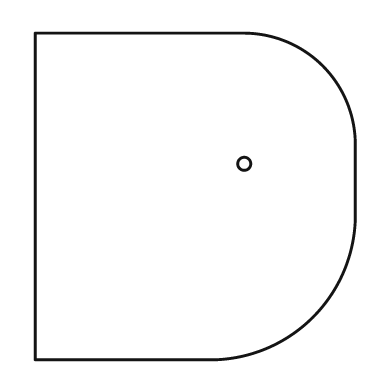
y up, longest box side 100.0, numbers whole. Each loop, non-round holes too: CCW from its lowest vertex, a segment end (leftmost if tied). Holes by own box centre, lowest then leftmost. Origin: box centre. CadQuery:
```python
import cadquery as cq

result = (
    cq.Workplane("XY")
    .moveTo(-49.0, -50.0)
    .lineTo(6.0, -50.0)
    .threePointArc((36.0, -37.0), (49.0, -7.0))
    .lineTo(49.0, 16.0)
    .threePointArc((39.0, 40.0), (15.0, 50.0))
    .lineTo(-49.0, 50.0)
    .close()
    .moveTo(15.0, 10.0)
    .circle(2.0)
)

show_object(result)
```